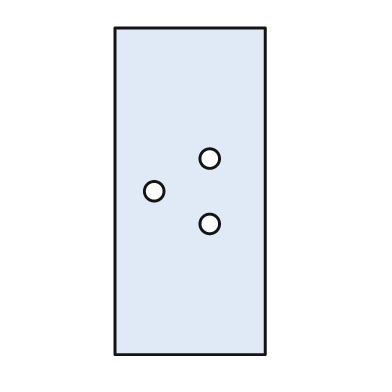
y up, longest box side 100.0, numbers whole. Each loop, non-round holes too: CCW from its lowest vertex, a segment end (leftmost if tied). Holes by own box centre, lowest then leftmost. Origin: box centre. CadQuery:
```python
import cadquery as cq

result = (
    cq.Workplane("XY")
    .moveTo(-23.0, -50.0)
    .lineTo(23.0, -50.0)
    .lineTo(23.0, 50.0)
    .lineTo(-23.0, 50.0)
    .close()
    .moveTo(6.0, -10.0)
    .circle(3.0)
    .moveTo(-11.0, 0.0)
    .circle(3.0)
    .moveTo(6.0, 10.0)
    .circle(3.0)
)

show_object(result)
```